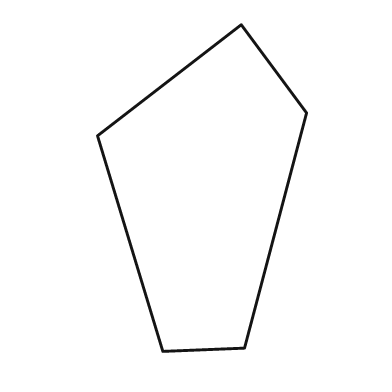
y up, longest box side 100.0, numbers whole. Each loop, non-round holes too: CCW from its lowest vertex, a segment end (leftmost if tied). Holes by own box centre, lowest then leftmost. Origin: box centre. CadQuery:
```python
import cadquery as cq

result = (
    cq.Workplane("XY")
    .moveTo(-12.0, -50.0)
    .lineTo(13.0, -49.0)
    .lineTo(32.0, 23.0)
    .lineTo(12.0, 50.0)
    .lineTo(-32.0, 16.0)
    .close()
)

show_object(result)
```